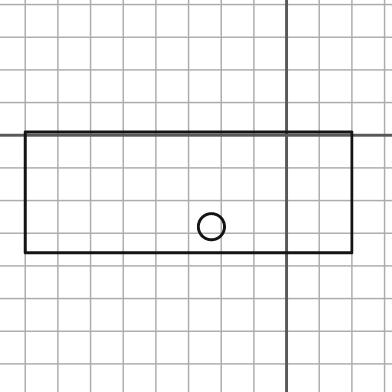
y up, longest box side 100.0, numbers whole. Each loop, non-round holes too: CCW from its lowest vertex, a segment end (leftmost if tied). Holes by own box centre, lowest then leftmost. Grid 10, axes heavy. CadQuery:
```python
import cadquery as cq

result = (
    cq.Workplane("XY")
    .moveTo(-80.0, -36.0)
    .lineTo(20.0, -36.0)
    .lineTo(20.0, 1.0)
    .lineTo(-80.0, 1.0)
    .close()
    .moveTo(-23.0, -28.0)
    .circle(4.0)
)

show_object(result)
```